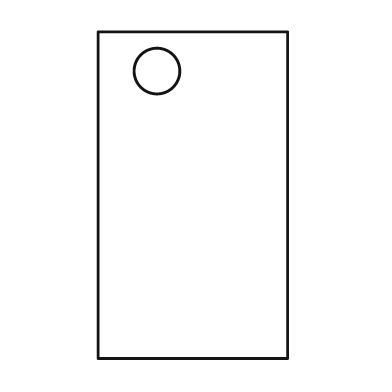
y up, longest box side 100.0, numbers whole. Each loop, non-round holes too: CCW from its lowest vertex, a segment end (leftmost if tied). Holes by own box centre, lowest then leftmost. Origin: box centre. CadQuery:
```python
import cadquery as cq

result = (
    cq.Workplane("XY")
    .moveTo(-29.0, -50.0)
    .lineTo(29.0, -50.0)
    .lineTo(29.0, 50.0)
    .lineTo(-29.0, 50.0)
    .close()
    .moveTo(-11.0, 38.0)
    .circle(7.0)
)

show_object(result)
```